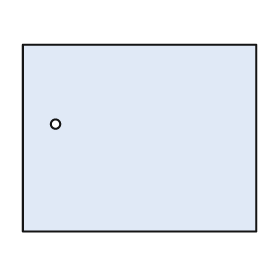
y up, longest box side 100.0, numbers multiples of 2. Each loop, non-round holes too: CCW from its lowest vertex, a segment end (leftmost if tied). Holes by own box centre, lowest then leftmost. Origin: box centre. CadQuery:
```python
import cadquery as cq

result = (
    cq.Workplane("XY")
    .moveTo(-50.0, -40.0)
    .lineTo(50.0, -40.0)
    .lineTo(50.0, 40.0)
    .lineTo(-50.0, 40.0)
    .close()
    .moveTo(-36.0, 6.0)
    .circle(2.0)
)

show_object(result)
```